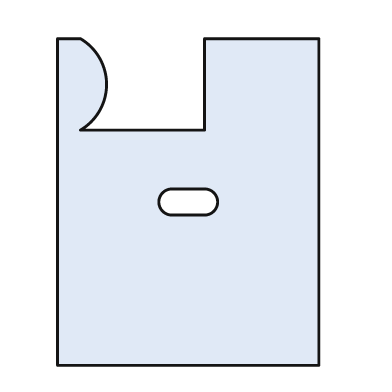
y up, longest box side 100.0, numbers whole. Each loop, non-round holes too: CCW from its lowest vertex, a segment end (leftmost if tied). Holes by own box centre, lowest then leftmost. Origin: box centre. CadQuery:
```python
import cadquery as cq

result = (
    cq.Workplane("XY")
    .moveTo(-40.0, -50.0)
    .lineTo(40.0, -50.0)
    .lineTo(40.0, 50.0)
    .lineTo(5.0, 50.0)
    .lineTo(5.0, 22.0)
    .lineTo(-33.0, 22.0)
    .threePointArc((-25.0, 36.0), (-33.0, 50.0))
    .lineTo(-40.0, 50.0)
    .close()
    .moveTo(-5.0, -4.0)
    .lineTo(5.0, -4.0)
    .threePointArc((9.0, 0.0), (5.0, 4.0))
    .lineTo(-5.0, 4.0)
    .threePointArc((-9.0, 0.0), (-5.0, -4.0))
    .close()
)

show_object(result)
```